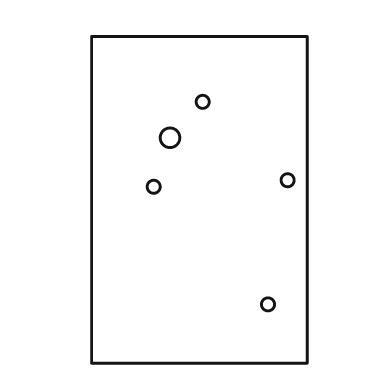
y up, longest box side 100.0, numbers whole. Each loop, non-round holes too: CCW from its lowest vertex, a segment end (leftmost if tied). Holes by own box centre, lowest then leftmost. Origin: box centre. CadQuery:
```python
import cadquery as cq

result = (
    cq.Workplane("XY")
    .moveTo(-33.0, -50.0)
    .lineTo(33.0, -50.0)
    .lineTo(33.0, 50.0)
    .lineTo(-33.0, 50.0)
    .close()
    .moveTo(21.0, -32.0)
    .circle(2.0)
    .moveTo(-14.0, 4.0)
    .circle(2.0)
    .moveTo(27.0, 6.0)
    .circle(2.0)
    .moveTo(-9.0, 19.0)
    .circle(3.0)
    .moveTo(1.0, 30.0)
    .circle(2.0)
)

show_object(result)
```